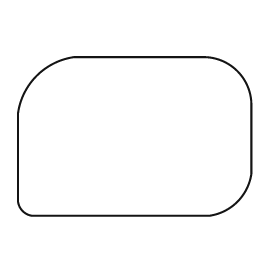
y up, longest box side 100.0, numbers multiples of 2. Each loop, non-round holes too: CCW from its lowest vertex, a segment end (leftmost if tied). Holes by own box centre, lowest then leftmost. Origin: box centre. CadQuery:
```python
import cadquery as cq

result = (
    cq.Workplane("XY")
    .moveTo(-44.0, -34.0)
    .lineTo(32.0, -34.0)
    .threePointArc((44.0, -28.0), (50.0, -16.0))
    .lineTo(50.0, 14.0)
    .threePointArc((44.0, 28.0), (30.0, 34.0))
    .lineTo(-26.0, 34.0)
    .threePointArc((-42.0, 26.0), (-50.0, 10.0))
    .lineTo(-50.0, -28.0)
    .threePointArc((-48.0, -32.0), (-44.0, -34.0))
    .close()
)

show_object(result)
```